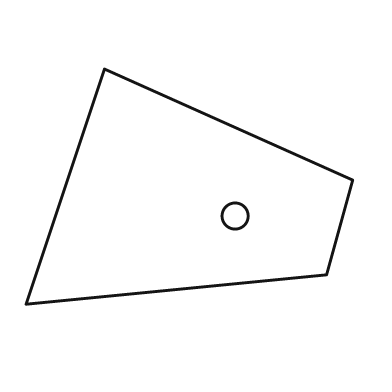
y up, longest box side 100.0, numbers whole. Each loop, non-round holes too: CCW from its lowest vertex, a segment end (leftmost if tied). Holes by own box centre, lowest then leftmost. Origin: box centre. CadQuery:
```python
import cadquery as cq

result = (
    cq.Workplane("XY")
    .moveTo(-50.0, -36.0)
    .lineTo(42.0, -27.0)
    .lineTo(50.0, 2.0)
    .lineTo(-26.0, 36.0)
    .close()
    .moveTo(14.0, -9.0)
    .circle(4.0)
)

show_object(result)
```